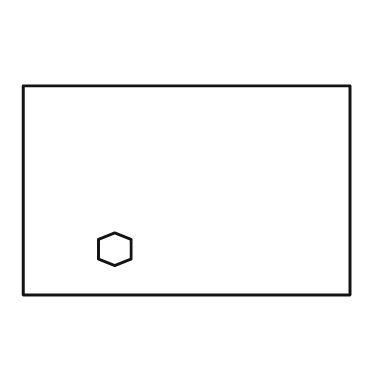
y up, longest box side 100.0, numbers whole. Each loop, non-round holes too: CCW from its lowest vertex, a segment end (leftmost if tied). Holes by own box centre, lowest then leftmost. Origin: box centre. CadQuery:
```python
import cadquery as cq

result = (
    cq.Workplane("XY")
    .moveTo(-50.0, -32.0)
    .lineTo(50.0, -32.0)
    .lineTo(50.0, 32.0)
    .lineTo(-50.0, 32.0)
    .close()
    .moveTo(-22.0, -23.0)
    .lineTo(-17.0, -21.0)
    .lineTo(-17.0, -15.0)
    .lineTo(-22.0, -13.0)
    .lineTo(-27.0, -15.0)
    .lineTo(-27.0, -21.0)
    .close()
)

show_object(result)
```